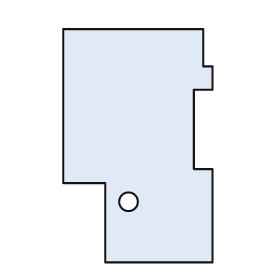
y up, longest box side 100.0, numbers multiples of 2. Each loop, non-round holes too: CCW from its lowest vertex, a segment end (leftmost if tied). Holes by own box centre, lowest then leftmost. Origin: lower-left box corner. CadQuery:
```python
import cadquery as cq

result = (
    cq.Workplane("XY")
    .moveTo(18.0, 0.0)
    .lineTo(64.0, 0.0)
    .lineTo(64.0, 40.0)
    .lineTo(56.0, 40.0)
    .lineTo(56.0, 74.0)
    .lineTo(64.0, 74.0)
    .lineTo(64.0, 84.0)
    .lineTo(60.0, 84.0)
    .lineTo(60.0, 100.0)
    .lineTo(0.0, 100.0)
    .lineTo(0.0, 34.0)
    .lineTo(18.0, 34.0)
    .close()
    .moveTo(28.0, 26.0)
    .circle(4.0)
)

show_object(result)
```